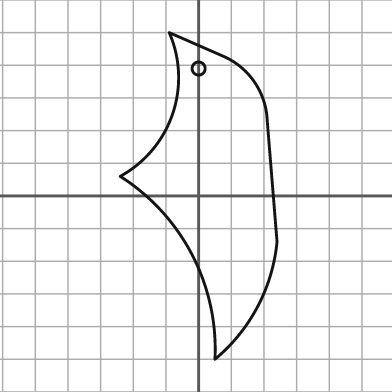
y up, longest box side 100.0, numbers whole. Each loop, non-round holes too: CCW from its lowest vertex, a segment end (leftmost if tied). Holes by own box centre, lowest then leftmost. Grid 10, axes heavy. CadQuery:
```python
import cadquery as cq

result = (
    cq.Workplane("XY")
    .moveTo(5.0, -50.0)
    .threePointArc((18.0, -34.0), (24.0, -14.0))
    .lineTo(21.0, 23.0)
    .threePointArc((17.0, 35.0), (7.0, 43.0))
    .lineTo(-9.0, 50.0)
    .threePointArc((-8.0, 25.0), (-24.0, 6.0))
    .threePointArc((-2.0, -18.0), (5.0, -50.0))
    .close()
    .moveTo(0.0, 39.0)
    .circle(2.0)
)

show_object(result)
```